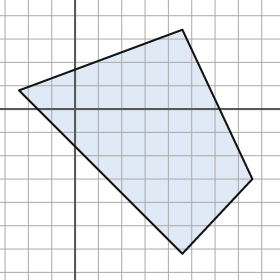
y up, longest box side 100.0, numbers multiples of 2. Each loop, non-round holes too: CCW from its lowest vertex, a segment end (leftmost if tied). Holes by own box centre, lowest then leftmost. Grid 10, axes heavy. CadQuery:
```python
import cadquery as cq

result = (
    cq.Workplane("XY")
    .moveTo(46.0, -62.0)
    .lineTo(76.0, -30.0)
    .lineTo(46.0, 34.0)
    .lineTo(-24.0, 8.0)
    .close()
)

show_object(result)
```